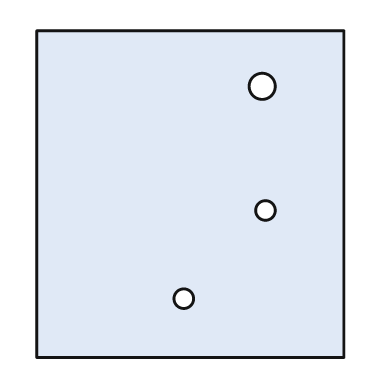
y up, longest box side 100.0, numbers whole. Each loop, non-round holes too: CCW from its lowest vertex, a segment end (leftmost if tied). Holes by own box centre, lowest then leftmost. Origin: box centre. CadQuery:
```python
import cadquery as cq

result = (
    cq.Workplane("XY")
    .moveTo(-47.0, -50.0)
    .lineTo(47.0, -50.0)
    .lineTo(47.0, 50.0)
    .lineTo(-47.0, 50.0)
    .close()
    .moveTo(-2.0, -32.0)
    .circle(3.0)
    .moveTo(23.0, -5.0)
    .circle(3.0)
    .moveTo(22.0, 33.0)
    .circle(4.0)
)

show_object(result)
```